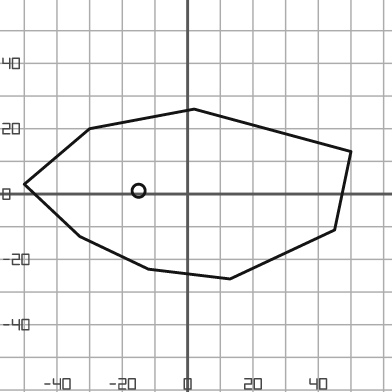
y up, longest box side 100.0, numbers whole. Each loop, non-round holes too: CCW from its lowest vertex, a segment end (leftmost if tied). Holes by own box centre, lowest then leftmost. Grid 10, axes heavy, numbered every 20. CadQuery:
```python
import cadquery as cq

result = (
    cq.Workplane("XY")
    .moveTo(13.0, -26.0)
    .lineTo(45.0, -11.0)
    .lineTo(50.0, 13.0)
    .lineTo(2.0, 26.0)
    .lineTo(-30.0, 20.0)
    .lineTo(-50.0, 3.0)
    .lineTo(-33.0, -13.0)
    .lineTo(-12.0, -23.0)
    .close()
    .moveTo(-15.0, 1.0)
    .circle(2.0)
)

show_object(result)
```